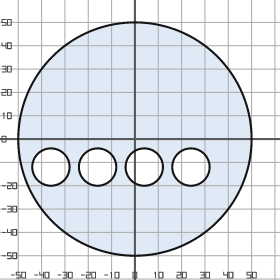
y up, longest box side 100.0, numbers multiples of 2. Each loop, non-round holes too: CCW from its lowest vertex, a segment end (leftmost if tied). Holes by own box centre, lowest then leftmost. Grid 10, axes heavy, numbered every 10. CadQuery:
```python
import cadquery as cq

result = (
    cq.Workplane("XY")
    .moveTo(0.0, 0.0)
    .circle(50.0)
    .moveTo(-36.0, -12.0)
    .circle(8.0)
    .moveTo(-16.0, -12.0)
    .circle(8.0)
    .moveTo(4.0, -12.0)
    .circle(8.0)
    .moveTo(24.0, -12.0)
    .circle(8.0)
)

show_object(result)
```